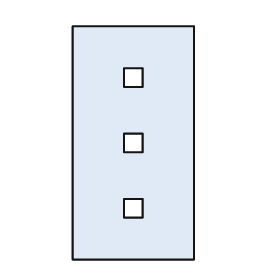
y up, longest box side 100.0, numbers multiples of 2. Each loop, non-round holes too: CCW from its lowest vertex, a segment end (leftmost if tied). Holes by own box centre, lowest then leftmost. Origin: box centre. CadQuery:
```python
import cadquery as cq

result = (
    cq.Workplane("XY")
    .moveTo(-26.0, -50.0)
    .lineTo(26.0, -50.0)
    .lineTo(26.0, 50.0)
    .lineTo(-26.0, 50.0)
    .close()
    .moveTo(-4.0, -32.0)
    .lineTo(4.0, -32.0)
    .lineTo(4.0, -24.0)
    .lineTo(-4.0, -24.0)
    .close()
    .moveTo(-4.0, -4.0)
    .lineTo(4.0, -4.0)
    .lineTo(4.0, 4.0)
    .lineTo(-4.0, 4.0)
    .close()
    .moveTo(-4.0, 24.0)
    .lineTo(4.0, 24.0)
    .lineTo(4.0, 32.0)
    .lineTo(-4.0, 32.0)
    .close()
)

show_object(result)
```